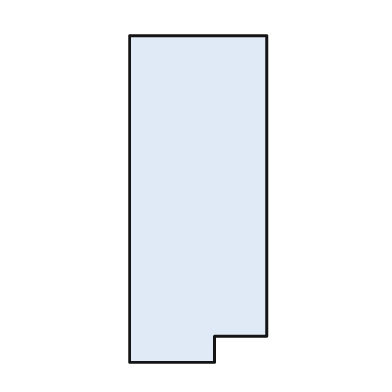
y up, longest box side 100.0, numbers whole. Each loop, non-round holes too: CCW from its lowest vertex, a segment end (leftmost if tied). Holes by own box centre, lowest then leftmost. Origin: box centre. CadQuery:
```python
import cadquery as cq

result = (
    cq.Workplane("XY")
    .moveTo(-21.0, -50.0)
    .lineTo(5.0, -50.0)
    .lineTo(5.0, -42.0)
    .lineTo(21.0, -42.0)
    .lineTo(21.0, 50.0)
    .lineTo(-21.0, 50.0)
    .close()
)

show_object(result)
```